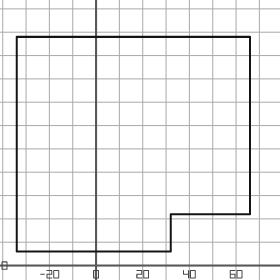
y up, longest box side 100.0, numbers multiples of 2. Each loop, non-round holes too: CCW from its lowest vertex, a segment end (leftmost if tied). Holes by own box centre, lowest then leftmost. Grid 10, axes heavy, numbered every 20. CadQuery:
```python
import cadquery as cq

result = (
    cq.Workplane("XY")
    .moveTo(-34.0, 6.0)
    .lineTo(32.0, 6.0)
    .lineTo(32.0, 22.0)
    .lineTo(66.0, 22.0)
    .lineTo(66.0, 98.0)
    .lineTo(-34.0, 98.0)
    .close()
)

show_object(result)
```